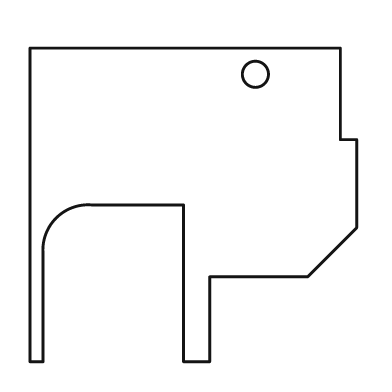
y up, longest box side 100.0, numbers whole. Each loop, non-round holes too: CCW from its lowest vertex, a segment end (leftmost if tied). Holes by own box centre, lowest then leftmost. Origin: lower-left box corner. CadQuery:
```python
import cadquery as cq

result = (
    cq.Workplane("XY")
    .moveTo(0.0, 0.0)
    .lineTo(4.0, 0.0)
    .lineTo(4.0, 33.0)
    .threePointArc((8.0, 44.0), (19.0, 48.0))
    .lineTo(47.0, 48.0)
    .lineTo(47.0, 0.0)
    .lineTo(55.0, 0.0)
    .lineTo(55.0, 26.0)
    .lineTo(85.0, 26.0)
    .lineTo(100.0, 41.0)
    .lineTo(100.0, 68.0)
    .lineTo(95.0, 68.0)
    .lineTo(95.0, 96.0)
    .lineTo(0.0, 96.0)
    .close()
    .moveTo(69.0, 88.0)
    .circle(4.0)
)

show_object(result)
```